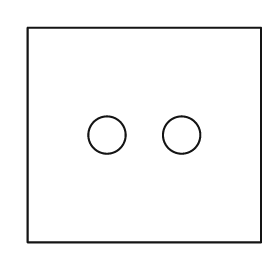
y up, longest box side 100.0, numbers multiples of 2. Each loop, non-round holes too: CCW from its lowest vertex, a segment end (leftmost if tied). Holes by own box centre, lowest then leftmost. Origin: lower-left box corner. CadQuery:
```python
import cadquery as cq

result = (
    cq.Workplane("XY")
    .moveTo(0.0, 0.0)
    .lineTo(100.0, 0.0)
    .lineTo(100.0, 92.0)
    .lineTo(0.0, 92.0)
    .close()
    .moveTo(34.0, 46.0)
    .circle(8.0)
    .moveTo(66.0, 46.0)
    .circle(8.0)
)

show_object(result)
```